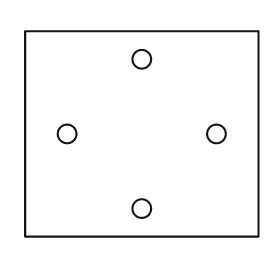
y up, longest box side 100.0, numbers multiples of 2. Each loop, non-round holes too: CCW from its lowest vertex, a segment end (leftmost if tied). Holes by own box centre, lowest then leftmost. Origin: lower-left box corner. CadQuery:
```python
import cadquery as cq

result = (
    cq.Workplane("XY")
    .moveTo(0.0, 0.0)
    .lineTo(100.0, 0.0)
    .lineTo(100.0, 88.0)
    .lineTo(0.0, 88.0)
    .close()
    .moveTo(50.0, 12.0)
    .circle(4.0)
    .moveTo(18.0, 44.0)
    .circle(4.0)
    .moveTo(82.0, 44.0)
    .circle(4.0)
    .moveTo(50.0, 76.0)
    .circle(4.0)
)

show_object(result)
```